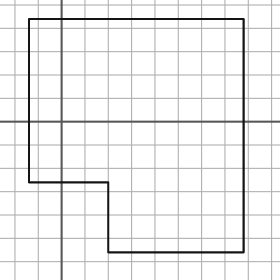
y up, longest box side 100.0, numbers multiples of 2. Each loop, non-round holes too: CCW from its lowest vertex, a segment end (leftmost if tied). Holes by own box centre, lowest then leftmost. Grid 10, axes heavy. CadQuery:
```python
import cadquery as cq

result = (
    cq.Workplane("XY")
    .moveTo(20.0, -56.0)
    .lineTo(78.0, -56.0)
    .lineTo(78.0, 44.0)
    .lineTo(-14.0, 44.0)
    .lineTo(-14.0, -26.0)
    .lineTo(20.0, -26.0)
    .close()
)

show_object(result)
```